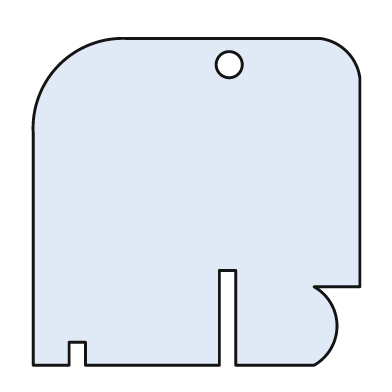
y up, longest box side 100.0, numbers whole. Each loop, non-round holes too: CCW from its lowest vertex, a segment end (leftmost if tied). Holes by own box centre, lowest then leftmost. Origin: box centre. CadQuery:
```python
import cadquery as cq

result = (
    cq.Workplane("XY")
    .moveTo(-50.0, -50.0)
    .lineTo(-39.0, -50.0)
    .lineTo(-39.0, -43.0)
    .lineTo(-34.0, -43.0)
    .lineTo(-34.0, -50.0)
    .lineTo(7.0, -50.0)
    .lineTo(7.0, -21.0)
    .lineTo(12.0, -21.0)
    .lineTo(12.0, -50.0)
    .lineTo(36.0, -50.0)
    .threePointArc((43.0, -38.0), (36.0, -26.0))
    .lineTo(50.0, -26.0)
    .lineTo(50.0, 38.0)
    .threePointArc((46.0, 46.0), (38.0, 50.0))
    .lineTo(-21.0, 50.0)
    .threePointArc((-42.0, 42.0), (-50.0, 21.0))
    .close()
    .moveTo(10.0, 42.0)
    .circle(4.0)
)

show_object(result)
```